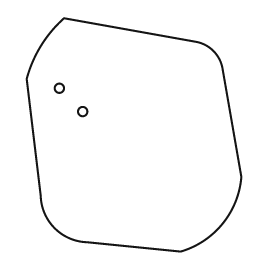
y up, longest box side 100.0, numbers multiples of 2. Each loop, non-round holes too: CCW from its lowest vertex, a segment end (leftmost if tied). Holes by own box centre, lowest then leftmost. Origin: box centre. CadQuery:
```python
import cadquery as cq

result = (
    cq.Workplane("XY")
    .moveTo(20.0, -50.0)
    .threePointArc((38.0, -38.0), (46.0, -18.0))
    .lineTo(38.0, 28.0)
    .threePointArc((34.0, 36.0), (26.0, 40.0))
    .lineTo(-30.0, 50.0)
    .threePointArc((-40.0, 38.0), (-46.0, 24.0))
    .lineTo(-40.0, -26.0)
    .threePointArc((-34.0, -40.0), (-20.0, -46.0))
    .close()
    .moveTo(-22.0, 10.0)
    .circle(2.0)
    .moveTo(-32.0, 20.0)
    .circle(2.0)
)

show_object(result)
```